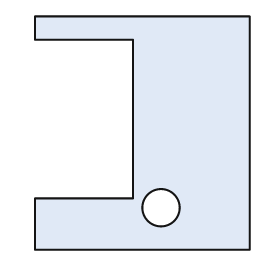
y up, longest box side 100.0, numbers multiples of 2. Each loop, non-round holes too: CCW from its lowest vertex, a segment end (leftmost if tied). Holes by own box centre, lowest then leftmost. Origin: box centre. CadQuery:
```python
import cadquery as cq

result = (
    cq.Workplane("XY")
    .moveTo(-46.0, -50.0)
    .lineTo(46.0, -50.0)
    .lineTo(46.0, 50.0)
    .lineTo(-46.0, 50.0)
    .lineTo(-46.0, 40.0)
    .lineTo(-4.0, 40.0)
    .lineTo(-4.0, -28.0)
    .lineTo(-46.0, -28.0)
    .close()
    .moveTo(8.0, -32.0)
    .circle(8.0)
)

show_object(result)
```